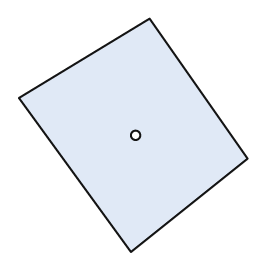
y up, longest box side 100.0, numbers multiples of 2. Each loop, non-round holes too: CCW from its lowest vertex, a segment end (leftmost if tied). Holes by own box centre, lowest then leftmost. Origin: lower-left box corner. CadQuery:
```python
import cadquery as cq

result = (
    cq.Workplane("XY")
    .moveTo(48.0, 0.0)
    .lineTo(98.0, 40.0)
    .lineTo(56.0, 100.0)
    .lineTo(0.0, 66.0)
    .close()
    .moveTo(50.0, 50.0)
    .circle(2.0)
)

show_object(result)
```